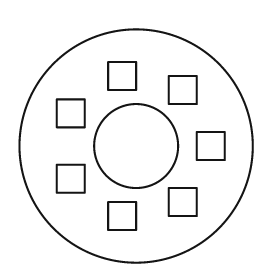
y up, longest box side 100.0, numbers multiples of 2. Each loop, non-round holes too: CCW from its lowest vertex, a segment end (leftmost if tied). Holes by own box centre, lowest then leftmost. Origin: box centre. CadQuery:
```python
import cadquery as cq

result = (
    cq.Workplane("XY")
    .moveTo(0.0, 0.0)
    .circle(50.0)
    .moveTo(-12.0, -36.0)
    .lineTo(0.0, -36.0)
    .lineTo(0.0, -24.0)
    .lineTo(-12.0, -24.0)
    .close()
    .moveTo(14.0, -30.0)
    .lineTo(26.0, -30.0)
    .lineTo(26.0, -18.0)
    .lineTo(14.0, -18.0)
    .close()
    .moveTo(-34.0, -20.0)
    .lineTo(-22.0, -20.0)
    .lineTo(-22.0, -8.0)
    .lineTo(-34.0, -8.0)
    .close()
    .moveTo(0.0, 0.0)
    .circle(18.0)
    .moveTo(26.0, -6.0)
    .lineTo(38.0, -6.0)
    .lineTo(38.0, 6.0)
    .lineTo(26.0, 6.0)
    .close()
    .moveTo(-34.0, 8.0)
    .lineTo(-22.0, 8.0)
    .lineTo(-22.0, 20.0)
    .lineTo(-34.0, 20.0)
    .close()
    .moveTo(14.0, 18.0)
    .lineTo(26.0, 18.0)
    .lineTo(26.0, 30.0)
    .lineTo(14.0, 30.0)
    .close()
    .moveTo(-12.0, 24.0)
    .lineTo(0.0, 24.0)
    .lineTo(0.0, 36.0)
    .lineTo(-12.0, 36.0)
    .close()
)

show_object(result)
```